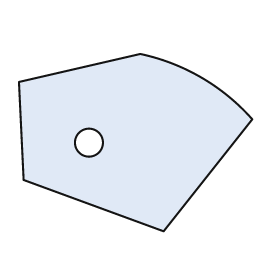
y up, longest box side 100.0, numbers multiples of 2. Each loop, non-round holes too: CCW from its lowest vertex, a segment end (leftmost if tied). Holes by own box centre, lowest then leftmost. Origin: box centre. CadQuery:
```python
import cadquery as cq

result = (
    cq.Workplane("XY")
    .moveTo(12.0, -38.0)
    .lineTo(50.0, 10.0)
    .threePointArc((28.0, 28.0), (2.0, 38.0))
    .lineTo(-50.0, 26.0)
    .lineTo(-48.0, -16.0)
    .close()
    .moveTo(-20.0, 0.0)
    .circle(6.0)
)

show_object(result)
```